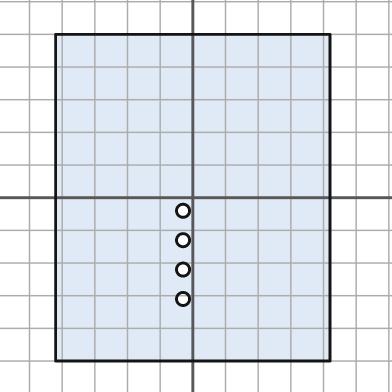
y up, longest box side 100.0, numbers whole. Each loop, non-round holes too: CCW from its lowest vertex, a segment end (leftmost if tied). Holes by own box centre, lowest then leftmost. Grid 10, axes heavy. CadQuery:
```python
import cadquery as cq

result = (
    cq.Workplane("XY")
    .moveTo(-42.0, -50.0)
    .lineTo(42.0, -50.0)
    .lineTo(42.0, 50.0)
    .lineTo(-42.0, 50.0)
    .close()
    .moveTo(-3.0, -31.0)
    .circle(2.0)
    .moveTo(-3.0, -22.0)
    .circle(2.0)
    .moveTo(-3.0, -13.0)
    .circle(2.0)
    .moveTo(-3.0, -4.0)
    .circle(2.0)
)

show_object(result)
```